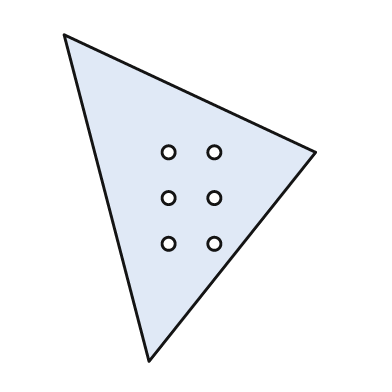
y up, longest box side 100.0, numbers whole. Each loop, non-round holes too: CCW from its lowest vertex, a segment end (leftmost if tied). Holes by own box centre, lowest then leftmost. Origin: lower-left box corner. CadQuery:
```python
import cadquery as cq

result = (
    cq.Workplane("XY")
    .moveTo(26.0, 0.0)
    .lineTo(77.0, 64.0)
    .lineTo(0.0, 100.0)
    .close()
    .moveTo(32.0, 36.0)
    .circle(2.0)
    .moveTo(46.0, 36.0)
    .circle(2.0)
    .moveTo(32.0, 50.0)
    .circle(2.0)
    .moveTo(46.0, 50.0)
    .circle(2.0)
    .moveTo(32.0, 64.0)
    .circle(2.0)
    .moveTo(46.0, 64.0)
    .circle(2.0)
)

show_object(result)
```